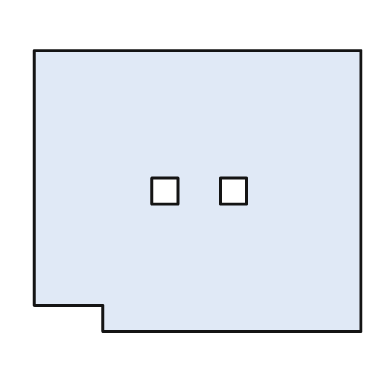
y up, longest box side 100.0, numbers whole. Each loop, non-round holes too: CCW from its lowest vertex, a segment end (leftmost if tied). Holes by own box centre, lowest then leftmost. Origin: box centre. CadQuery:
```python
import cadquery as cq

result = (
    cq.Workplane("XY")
    .moveTo(-29.0, -43.0)
    .lineTo(50.0, -43.0)
    .lineTo(50.0, 43.0)
    .lineTo(-50.0, 43.0)
    .lineTo(-50.0, -35.0)
    .lineTo(-29.0, -35.0)
    .close()
    .moveTo(-14.0, -4.0)
    .lineTo(-6.0, -4.0)
    .lineTo(-6.0, 4.0)
    .lineTo(-14.0, 4.0)
    .close()
    .moveTo(7.0, -4.0)
    .lineTo(15.0, -4.0)
    .lineTo(15.0, 4.0)
    .lineTo(7.0, 4.0)
    .close()
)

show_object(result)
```